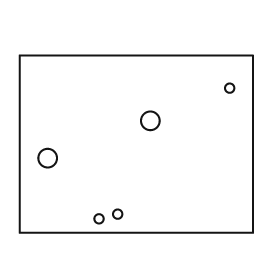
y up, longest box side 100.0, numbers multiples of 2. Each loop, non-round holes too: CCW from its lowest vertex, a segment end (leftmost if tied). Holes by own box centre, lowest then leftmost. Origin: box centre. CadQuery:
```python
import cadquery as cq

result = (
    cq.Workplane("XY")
    .moveTo(-50.0, -38.0)
    .lineTo(50.0, -38.0)
    .lineTo(50.0, 38.0)
    .lineTo(-50.0, 38.0)
    .close()
    .moveTo(-16.0, -32.0)
    .circle(2.0)
    .moveTo(-8.0, -30.0)
    .circle(2.0)
    .moveTo(-38.0, -6.0)
    .circle(4.0)
    .moveTo(6.0, 10.0)
    .circle(4.0)
    .moveTo(40.0, 24.0)
    .circle(2.0)
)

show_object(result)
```